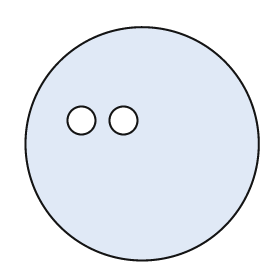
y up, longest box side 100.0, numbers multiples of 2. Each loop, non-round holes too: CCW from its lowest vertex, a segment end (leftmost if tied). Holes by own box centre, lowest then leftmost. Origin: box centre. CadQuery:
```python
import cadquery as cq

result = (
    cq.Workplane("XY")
    .moveTo(0.0, 0.0)
    .circle(50.0)
    .moveTo(-26.0, 10.0)
    .circle(6.0)
    .moveTo(-8.0, 10.0)
    .circle(6.0)
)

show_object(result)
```